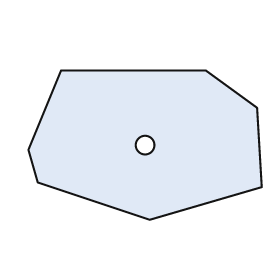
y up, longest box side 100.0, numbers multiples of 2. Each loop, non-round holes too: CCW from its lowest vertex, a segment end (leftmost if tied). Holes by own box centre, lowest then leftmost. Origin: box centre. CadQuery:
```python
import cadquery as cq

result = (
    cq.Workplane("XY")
    .moveTo(2.0, -32.0)
    .lineTo(50.0, -18.0)
    .lineTo(48.0, 16.0)
    .lineTo(26.0, 32.0)
    .lineTo(-36.0, 32.0)
    .lineTo(-50.0, -2.0)
    .lineTo(-46.0, -16.0)
    .close()
    .moveTo(0.0, 0.0)
    .circle(4.0)
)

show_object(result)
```